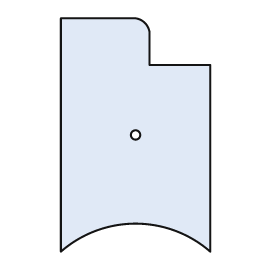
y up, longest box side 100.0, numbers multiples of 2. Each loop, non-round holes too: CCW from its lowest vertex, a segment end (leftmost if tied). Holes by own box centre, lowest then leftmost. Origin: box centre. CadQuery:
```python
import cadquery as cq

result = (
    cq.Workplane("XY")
    .moveTo(-32.0, -50.0)
    .threePointArc((0.0, -38.0), (32.0, -50.0))
    .lineTo(32.0, 30.0)
    .lineTo(6.0, 30.0)
    .lineTo(6.0, 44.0)
    .threePointArc((4.0, 48.0), (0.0, 50.0))
    .lineTo(-32.0, 50.0)
    .close()
    .moveTo(0.0, 0.0)
    .circle(2.0)
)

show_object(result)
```